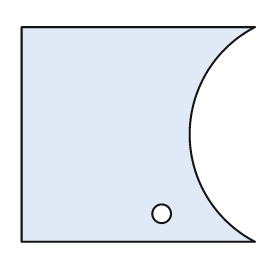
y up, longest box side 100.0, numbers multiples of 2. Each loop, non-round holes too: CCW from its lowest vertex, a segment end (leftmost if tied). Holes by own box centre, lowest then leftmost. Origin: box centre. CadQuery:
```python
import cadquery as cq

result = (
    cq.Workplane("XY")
    .moveTo(-50.0, -46.0)
    .lineTo(50.0, -46.0)
    .threePointArc((22.0, 0.0), (50.0, 46.0))
    .lineTo(-50.0, 46.0)
    .close()
    .moveTo(10.0, -34.0)
    .circle(4.0)
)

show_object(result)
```